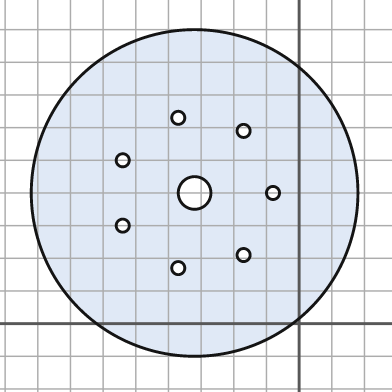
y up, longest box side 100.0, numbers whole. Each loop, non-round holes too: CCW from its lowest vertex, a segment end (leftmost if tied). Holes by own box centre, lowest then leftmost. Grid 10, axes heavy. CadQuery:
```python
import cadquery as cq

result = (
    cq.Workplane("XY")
    .moveTo(-32.0, 40.0)
    .circle(50.0)
    .moveTo(-37.0, 17.0)
    .circle(2.0)
    .moveTo(-17.0, 21.0)
    .circle(2.0)
    .moveTo(-54.0, 30.0)
    .circle(2.0)
    .moveTo(-32.0, 40.0)
    .circle(5.0)
    .moveTo(-8.0, 40.0)
    .circle(2.0)
    .moveTo(-54.0, 50.0)
    .circle(2.0)
    .moveTo(-17.0, 59.0)
    .circle(2.0)
    .moveTo(-37.0, 63.0)
    .circle(2.0)
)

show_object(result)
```